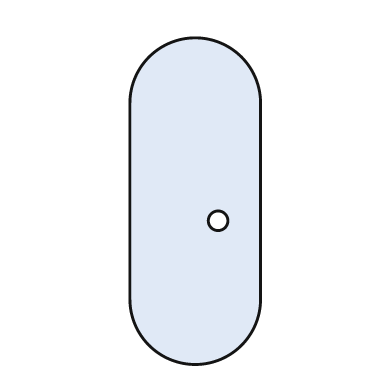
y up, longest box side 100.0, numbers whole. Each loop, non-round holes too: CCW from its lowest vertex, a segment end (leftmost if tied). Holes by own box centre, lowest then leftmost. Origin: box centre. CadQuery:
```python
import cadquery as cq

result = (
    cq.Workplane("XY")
    .moveTo(-20.0, -30.0)
    .threePointArc((0.0, -50.0), (20.0, -30.0))
    .lineTo(20.0, 30.0)
    .threePointArc((0.0, 50.0), (-20.0, 30.0))
    .close()
    .moveTo(7.0, -6.0)
    .circle(3.0)
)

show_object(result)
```